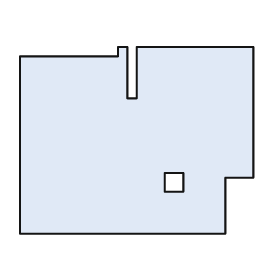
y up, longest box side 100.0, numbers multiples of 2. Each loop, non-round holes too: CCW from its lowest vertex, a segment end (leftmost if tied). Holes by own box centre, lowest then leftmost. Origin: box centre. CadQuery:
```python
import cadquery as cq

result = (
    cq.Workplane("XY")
    .moveTo(-50.0, -40.0)
    .lineTo(38.0, -40.0)
    .lineTo(38.0, -16.0)
    .lineTo(50.0, -16.0)
    .lineTo(50.0, 40.0)
    .lineTo(0.0, 40.0)
    .lineTo(0.0, 18.0)
    .lineTo(-4.0, 18.0)
    .lineTo(-4.0, 40.0)
    .lineTo(-8.0, 40.0)
    .lineTo(-8.0, 36.0)
    .lineTo(-50.0, 36.0)
    .close()
    .moveTo(12.0, -22.0)
    .lineTo(20.0, -22.0)
    .lineTo(20.0, -14.0)
    .lineTo(12.0, -14.0)
    .close()
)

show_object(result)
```